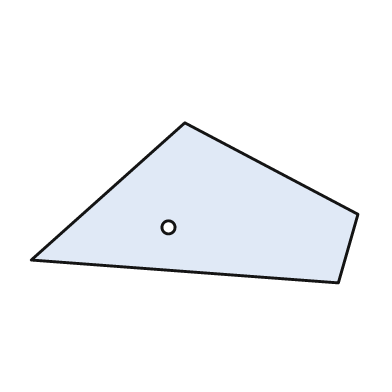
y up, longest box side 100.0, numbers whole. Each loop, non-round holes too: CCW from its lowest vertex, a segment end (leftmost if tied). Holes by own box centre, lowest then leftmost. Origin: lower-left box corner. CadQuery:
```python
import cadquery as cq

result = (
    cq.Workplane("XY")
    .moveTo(94.0, 0.0)
    .lineTo(100.0, 21.0)
    .lineTo(47.0, 49.0)
    .lineTo(0.0, 7.0)
    .close()
    .moveTo(42.0, 17.0)
    .circle(2.0)
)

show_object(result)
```